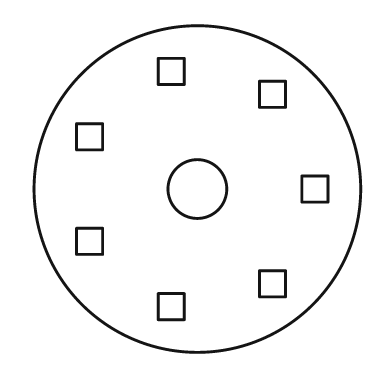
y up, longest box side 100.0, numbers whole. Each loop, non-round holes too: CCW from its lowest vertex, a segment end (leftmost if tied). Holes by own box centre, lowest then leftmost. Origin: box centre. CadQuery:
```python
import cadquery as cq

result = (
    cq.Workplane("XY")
    .moveTo(0.0, 0.0)
    .circle(50.0)
    .moveTo(-12.0, -40.0)
    .lineTo(-4.0, -40.0)
    .lineTo(-4.0, -32.0)
    .lineTo(-12.0, -32.0)
    .close()
    .moveTo(19.0, -33.0)
    .lineTo(27.0, -33.0)
    .lineTo(27.0, -25.0)
    .lineTo(19.0, -25.0)
    .close()
    .moveTo(-37.0, -20.0)
    .lineTo(-29.0, -20.0)
    .lineTo(-29.0, -12.0)
    .lineTo(-37.0, -12.0)
    .close()
    .moveTo(0.0, 0.0)
    .circle(9.0)
    .moveTo(32.0, -4.0)
    .lineTo(40.0, -4.0)
    .lineTo(40.0, 4.0)
    .lineTo(32.0, 4.0)
    .close()
    .moveTo(-37.0, 12.0)
    .lineTo(-29.0, 12.0)
    .lineTo(-29.0, 20.0)
    .lineTo(-37.0, 20.0)
    .close()
    .moveTo(19.0, 25.0)
    .lineTo(27.0, 25.0)
    .lineTo(27.0, 33.0)
    .lineTo(19.0, 33.0)
    .close()
    .moveTo(-12.0, 32.0)
    .lineTo(-4.0, 32.0)
    .lineTo(-4.0, 40.0)
    .lineTo(-12.0, 40.0)
    .close()
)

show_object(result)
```